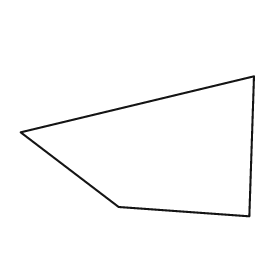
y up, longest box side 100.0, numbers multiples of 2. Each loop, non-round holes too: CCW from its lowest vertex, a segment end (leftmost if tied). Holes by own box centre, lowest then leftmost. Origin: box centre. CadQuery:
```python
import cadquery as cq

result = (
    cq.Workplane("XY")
    .moveTo(48.0, -30.0)
    .lineTo(50.0, 30.0)
    .lineTo(-50.0, 6.0)
    .lineTo(-8.0, -26.0)
    .close()
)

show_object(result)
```